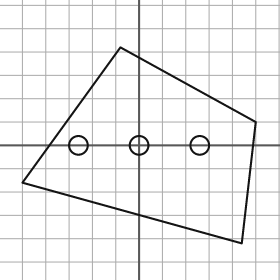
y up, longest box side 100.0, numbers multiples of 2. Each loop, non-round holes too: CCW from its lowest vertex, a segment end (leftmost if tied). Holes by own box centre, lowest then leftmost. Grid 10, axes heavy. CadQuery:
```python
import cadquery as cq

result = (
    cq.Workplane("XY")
    .moveTo(44.0, -42.0)
    .lineTo(50.0, 10.0)
    .lineTo(-8.0, 42.0)
    .lineTo(-50.0, -16.0)
    .close()
    .moveTo(-26.0, 0.0)
    .circle(4.0)
    .moveTo(0.0, 0.0)
    .circle(4.0)
    .moveTo(26.0, 0.0)
    .circle(4.0)
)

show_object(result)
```